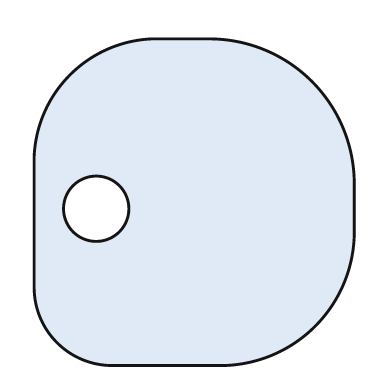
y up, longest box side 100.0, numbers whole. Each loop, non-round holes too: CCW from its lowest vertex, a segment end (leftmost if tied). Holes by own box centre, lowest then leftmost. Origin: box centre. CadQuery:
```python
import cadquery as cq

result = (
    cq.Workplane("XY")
    .moveTo(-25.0, -50.0)
    .lineTo(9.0, -50.0)
    .threePointArc((37.0, -38.0), (49.0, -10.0))
    .lineTo(49.0, 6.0)
    .threePointArc((36.0, 37.0), (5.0, 50.0))
    .lineTo(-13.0, 50.0)
    .threePointArc((-38.0, 39.0), (-49.0, 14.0))
    .lineTo(-49.0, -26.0)
    .threePointArc((-42.0, -43.0), (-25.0, -50.0))
    .close()
    .moveTo(-30.0, -2.0)
    .circle(10.0)
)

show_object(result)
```